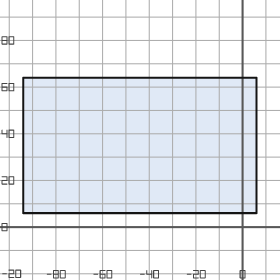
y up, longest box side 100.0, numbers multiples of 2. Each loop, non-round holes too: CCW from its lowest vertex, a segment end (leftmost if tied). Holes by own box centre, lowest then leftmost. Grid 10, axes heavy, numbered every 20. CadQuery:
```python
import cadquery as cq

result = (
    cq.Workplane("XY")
    .moveTo(-94.0, 6.0)
    .lineTo(6.0, 6.0)
    .lineTo(6.0, 64.0)
    .lineTo(-94.0, 64.0)
    .close()
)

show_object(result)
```